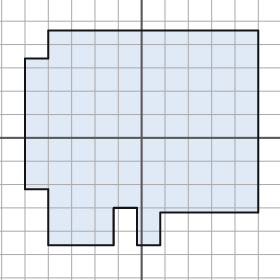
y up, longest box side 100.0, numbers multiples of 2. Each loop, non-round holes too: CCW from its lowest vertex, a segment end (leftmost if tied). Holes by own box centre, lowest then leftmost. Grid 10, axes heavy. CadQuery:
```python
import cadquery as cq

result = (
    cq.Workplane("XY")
    .moveTo(-40.0, -46.0)
    .lineTo(-12.0, -46.0)
    .lineTo(-12.0, -30.0)
    .lineTo(-2.0, -30.0)
    .lineTo(-2.0, -46.0)
    .lineTo(8.0, -46.0)
    .lineTo(8.0, -32.0)
    .lineTo(50.0, -32.0)
    .lineTo(50.0, 46.0)
    .lineTo(-40.0, 46.0)
    .lineTo(-40.0, 34.0)
    .lineTo(-50.0, 34.0)
    .lineTo(-50.0, -22.0)
    .lineTo(-40.0, -22.0)
    .close()
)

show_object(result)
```